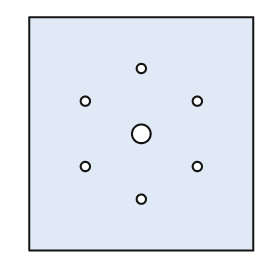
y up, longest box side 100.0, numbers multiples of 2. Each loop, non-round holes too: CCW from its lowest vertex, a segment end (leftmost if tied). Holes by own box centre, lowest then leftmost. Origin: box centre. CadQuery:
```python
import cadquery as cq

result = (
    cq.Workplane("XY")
    .moveTo(-48.0, -50.0)
    .lineTo(48.0, -50.0)
    .lineTo(48.0, 50.0)
    .lineTo(-48.0, 50.0)
    .close()
    .moveTo(0.0, -28.0)
    .circle(2.0)
    .moveTo(-24.0, -14.0)
    .circle(2.0)
    .moveTo(24.0, -14.0)
    .circle(2.0)
    .moveTo(0.0, 0.0)
    .circle(4.0)
    .moveTo(-24.0, 14.0)
    .circle(2.0)
    .moveTo(24.0, 14.0)
    .circle(2.0)
    .moveTo(0.0, 28.0)
    .circle(2.0)
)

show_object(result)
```